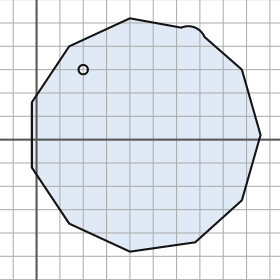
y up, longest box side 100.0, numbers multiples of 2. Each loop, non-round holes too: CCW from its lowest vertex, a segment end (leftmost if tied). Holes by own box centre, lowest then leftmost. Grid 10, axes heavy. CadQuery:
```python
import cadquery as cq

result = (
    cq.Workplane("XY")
    .moveTo(40.0, -48.0)
    .lineTo(68.0, -44.0)
    .lineTo(88.0, -26.0)
    .lineTo(96.0, 2.0)
    .lineTo(88.0, 30.0)
    .lineTo(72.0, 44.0)
    .threePointArc((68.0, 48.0), (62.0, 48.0))
    .lineTo(40.0, 52.0)
    .lineTo(14.0, 40.0)
    .lineTo(-2.0, 16.0)
    .lineTo(-2.0, -12.0)
    .lineTo(14.0, -36.0)
    .close()
    .moveTo(20.0, 30.0)
    .circle(2.0)
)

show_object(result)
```